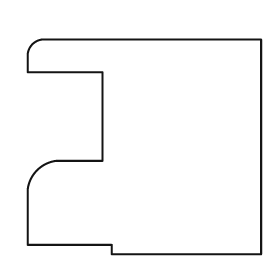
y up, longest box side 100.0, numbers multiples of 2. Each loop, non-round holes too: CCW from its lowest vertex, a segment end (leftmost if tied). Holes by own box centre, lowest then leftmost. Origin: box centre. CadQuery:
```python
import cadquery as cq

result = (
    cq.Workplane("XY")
    .moveTo(-14.0, -46.0)
    .lineTo(50.0, -46.0)
    .lineTo(50.0, 46.0)
    .lineTo(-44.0, 46.0)
    .threePointArc((-48.0, 44.0), (-50.0, 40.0))
    .lineTo(-50.0, 32.0)
    .lineTo(-18.0, 32.0)
    .lineTo(-18.0, -6.0)
    .lineTo(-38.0, -6.0)
    .threePointArc((-46.0, -10.0), (-50.0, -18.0))
    .lineTo(-50.0, -42.0)
    .lineTo(-14.0, -42.0)
    .close()
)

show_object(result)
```